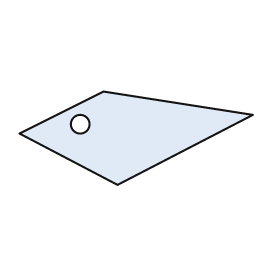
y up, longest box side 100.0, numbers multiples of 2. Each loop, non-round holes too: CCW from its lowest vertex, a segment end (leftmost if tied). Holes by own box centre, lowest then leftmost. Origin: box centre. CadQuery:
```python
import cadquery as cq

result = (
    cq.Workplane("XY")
    .moveTo(-8.0, -20.0)
    .lineTo(50.0, 10.0)
    .lineTo(-14.0, 20.0)
    .lineTo(-50.0, 2.0)
    .close()
    .moveTo(-24.0, 6.0)
    .circle(4.0)
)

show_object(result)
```